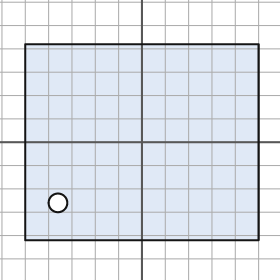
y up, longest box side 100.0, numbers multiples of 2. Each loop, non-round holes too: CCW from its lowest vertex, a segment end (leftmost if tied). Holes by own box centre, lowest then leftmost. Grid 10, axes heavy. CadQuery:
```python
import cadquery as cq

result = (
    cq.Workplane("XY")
    .moveTo(-50.0, -42.0)
    .lineTo(50.0, -42.0)
    .lineTo(50.0, 42.0)
    .lineTo(-50.0, 42.0)
    .close()
    .moveTo(-36.0, -26.0)
    .circle(4.0)
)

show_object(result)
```